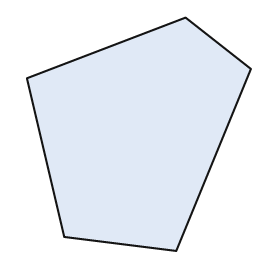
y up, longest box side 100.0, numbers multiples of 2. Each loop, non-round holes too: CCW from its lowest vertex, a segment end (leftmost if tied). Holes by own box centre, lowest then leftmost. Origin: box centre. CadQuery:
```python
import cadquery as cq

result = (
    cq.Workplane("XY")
    .moveTo(16.0, -50.0)
    .lineTo(48.0, 28.0)
    .lineTo(20.0, 50.0)
    .lineTo(-48.0, 24.0)
    .lineTo(-32.0, -44.0)
    .close()
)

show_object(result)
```